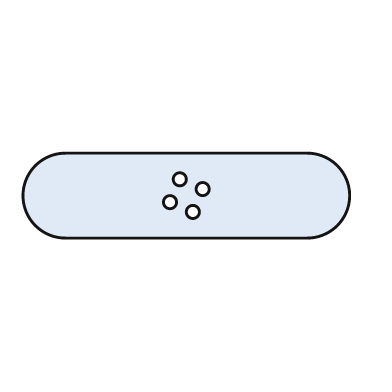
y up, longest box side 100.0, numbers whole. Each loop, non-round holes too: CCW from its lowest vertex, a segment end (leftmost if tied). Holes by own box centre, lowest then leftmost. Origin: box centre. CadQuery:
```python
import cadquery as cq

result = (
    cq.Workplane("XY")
    .moveTo(-37.0, -13.0)
    .lineTo(37.0, -13.0)
    .threePointArc((50.0, 0.0), (37.0, 13.0))
    .lineTo(-37.0, 13.0)
    .threePointArc((-50.0, 0.0), (-37.0, -13.0))
    .close()
    .moveTo(2.0, -5.0)
    .circle(2.0)
    .moveTo(-5.0, -2.0)
    .circle(2.0)
    .moveTo(5.0, 2.0)
    .circle(2.0)
    .moveTo(-2.0, 5.0)
    .circle(2.0)
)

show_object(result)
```